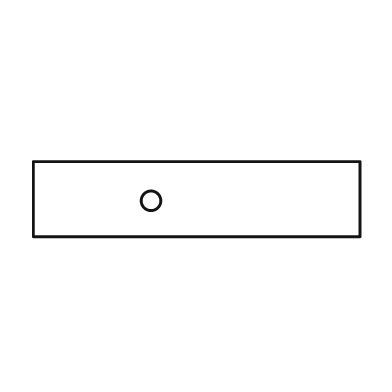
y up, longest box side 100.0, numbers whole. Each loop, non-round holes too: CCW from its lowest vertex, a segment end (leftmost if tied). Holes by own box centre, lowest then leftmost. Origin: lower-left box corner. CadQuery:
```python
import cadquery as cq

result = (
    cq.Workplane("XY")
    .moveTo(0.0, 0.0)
    .lineTo(100.0, 0.0)
    .lineTo(100.0, 23.0)
    .lineTo(0.0, 23.0)
    .close()
    .moveTo(36.0, 11.0)
    .circle(3.0)
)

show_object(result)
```